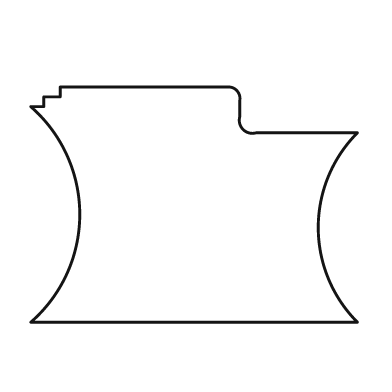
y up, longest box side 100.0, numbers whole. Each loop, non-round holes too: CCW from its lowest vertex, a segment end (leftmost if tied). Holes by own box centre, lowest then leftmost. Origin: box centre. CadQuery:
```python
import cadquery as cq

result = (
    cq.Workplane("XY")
    .moveTo(-50.0, -36.0)
    .lineTo(50.0, -36.0)
    .threePointArc((38.0, -7.0), (50.0, 22.0))
    .lineTo(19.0, 22.0)
    .threePointArc((15.0, 23.0), (14.0, 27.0))
    .lineTo(14.0, 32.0)
    .threePointArc((13.0, 35.0), (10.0, 36.0))
    .lineTo(-41.0, 36.0)
    .lineTo(-41.0, 33.0)
    .lineTo(-46.0, 33.0)
    .lineTo(-46.0, 30.0)
    .lineTo(-50.0, 30.0)
    .threePointArc((-35.0, -3.0), (-50.0, -36.0))
    .close()
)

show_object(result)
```